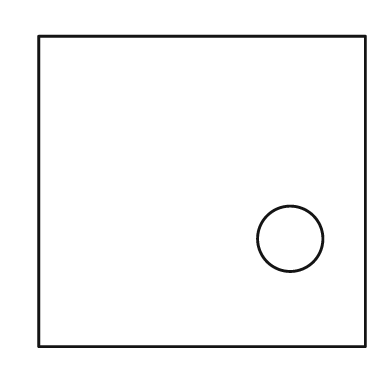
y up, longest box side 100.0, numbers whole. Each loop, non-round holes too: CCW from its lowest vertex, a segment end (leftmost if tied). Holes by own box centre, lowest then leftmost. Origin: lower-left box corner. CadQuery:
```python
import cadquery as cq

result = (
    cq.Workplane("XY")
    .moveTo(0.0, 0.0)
    .lineTo(100.0, 0.0)
    .lineTo(100.0, 95.0)
    .lineTo(0.0, 95.0)
    .close()
    .moveTo(77.0, 33.0)
    .circle(10.0)
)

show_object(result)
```